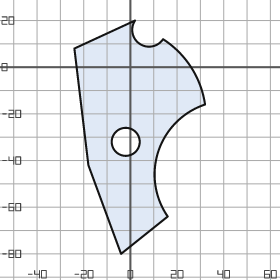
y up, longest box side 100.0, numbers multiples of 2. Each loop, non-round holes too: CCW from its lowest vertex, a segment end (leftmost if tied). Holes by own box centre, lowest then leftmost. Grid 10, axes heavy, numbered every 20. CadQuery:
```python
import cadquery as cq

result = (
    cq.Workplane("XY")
    .moveTo(-4.0, -80.0)
    .lineTo(16.0, -64.0)
    .threePointArc((12.0, -36.0), (32.0, -16.0))
    .threePointArc((26.0, 0.0), (14.0, 12.0))
    .threePointArc((4.0, 10.0), (2.0, 20.0))
    .lineTo(-24.0, 8.0)
    .lineTo(-18.0, -42.0)
    .close()
    .moveTo(-2.0, -32.0)
    .circle(6.0)
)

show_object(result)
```